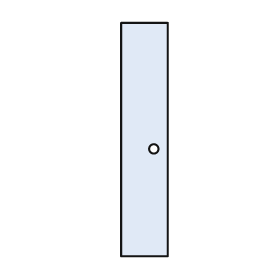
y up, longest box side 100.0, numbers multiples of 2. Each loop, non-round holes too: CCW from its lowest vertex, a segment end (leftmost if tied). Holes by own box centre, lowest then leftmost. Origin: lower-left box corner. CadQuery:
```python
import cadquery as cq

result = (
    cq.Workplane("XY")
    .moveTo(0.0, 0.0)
    .lineTo(20.0, 0.0)
    .lineTo(20.0, 100.0)
    .lineTo(0.0, 100.0)
    .close()
    .moveTo(14.0, 46.0)
    .circle(2.0)
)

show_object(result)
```